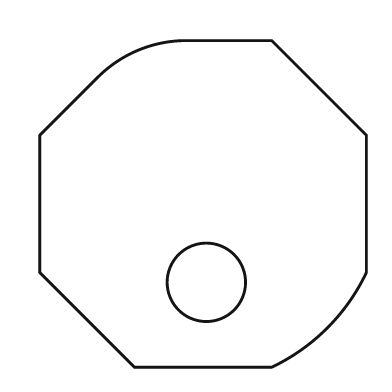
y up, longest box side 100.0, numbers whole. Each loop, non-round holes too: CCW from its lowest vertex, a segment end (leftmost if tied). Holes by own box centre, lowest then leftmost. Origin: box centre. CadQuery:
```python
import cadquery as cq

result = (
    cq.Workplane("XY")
    .moveTo(-21.0, -50.0)
    .lineTo(21.0, -50.0)
    .threePointArc((38.0, -38.0), (50.0, -21.0))
    .lineTo(50.0, 21.0)
    .lineTo(21.0, 50.0)
    .lineTo(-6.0, 50.0)
    .threePointArc((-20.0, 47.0), (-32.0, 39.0))
    .lineTo(-50.0, 21.0)
    .lineTo(-50.0, -21.0)
    .close()
    .moveTo(1.0, -24.0)
    .circle(12.0)
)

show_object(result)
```